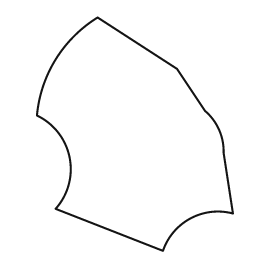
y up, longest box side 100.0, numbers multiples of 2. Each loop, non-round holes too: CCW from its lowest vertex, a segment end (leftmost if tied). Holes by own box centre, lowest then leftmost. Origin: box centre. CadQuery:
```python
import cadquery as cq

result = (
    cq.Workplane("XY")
    .moveTo(12.0, -50.0)
    .threePointArc((24.0, -36.0), (42.0, -34.0))
    .lineTo(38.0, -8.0)
    .threePointArc((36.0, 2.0), (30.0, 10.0))
    .lineTo(18.0, 28.0)
    .lineTo(-16.0, 50.0)
    .threePointArc((-34.0, 32.0), (-42.0, 8.0))
    .threePointArc((-28.0, -10.0), (-34.0, -32.0))
    .close()
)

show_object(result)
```